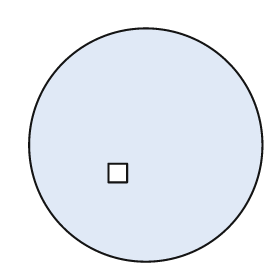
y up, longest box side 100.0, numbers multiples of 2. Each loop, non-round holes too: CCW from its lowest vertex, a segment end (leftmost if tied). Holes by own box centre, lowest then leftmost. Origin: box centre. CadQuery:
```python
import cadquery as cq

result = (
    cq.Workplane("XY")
    .moveTo(0.0, 0.0)
    .circle(50.0)
    .moveTo(-16.0, -16.0)
    .lineTo(-8.0, -16.0)
    .lineTo(-8.0, -8.0)
    .lineTo(-16.0, -8.0)
    .close()
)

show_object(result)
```